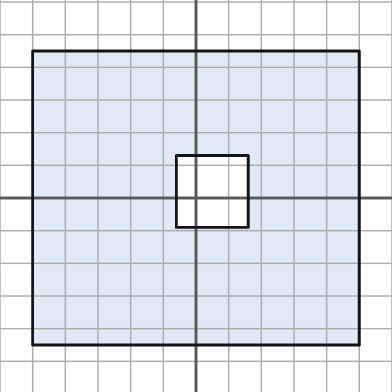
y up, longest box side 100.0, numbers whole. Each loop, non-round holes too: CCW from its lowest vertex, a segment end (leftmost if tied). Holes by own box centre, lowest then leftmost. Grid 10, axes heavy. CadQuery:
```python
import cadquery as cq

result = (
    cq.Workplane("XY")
    .moveTo(-50.0, -45.0)
    .lineTo(50.0, -45.0)
    .lineTo(50.0, 45.0)
    .lineTo(-50.0, 45.0)
    .close()
    .moveTo(-6.0, -9.0)
    .lineTo(16.0, -9.0)
    .lineTo(16.0, 13.0)
    .lineTo(-6.0, 13.0)
    .close()
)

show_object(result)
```